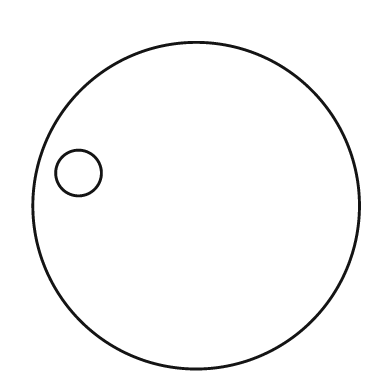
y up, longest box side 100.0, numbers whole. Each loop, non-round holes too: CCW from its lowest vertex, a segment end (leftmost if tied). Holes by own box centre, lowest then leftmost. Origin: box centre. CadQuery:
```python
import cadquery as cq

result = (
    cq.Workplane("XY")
    .moveTo(0.0, 0.0)
    .circle(50.0)
    .moveTo(-36.0, 10.0)
    .circle(7.0)
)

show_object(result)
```